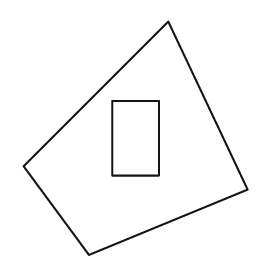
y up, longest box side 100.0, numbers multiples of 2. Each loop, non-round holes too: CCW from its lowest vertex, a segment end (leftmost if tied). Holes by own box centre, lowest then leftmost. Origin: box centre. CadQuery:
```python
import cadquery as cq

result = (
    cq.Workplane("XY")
    .moveTo(-20.0, -50.0)
    .lineTo(48.0, -22.0)
    .lineTo(14.0, 50.0)
    .lineTo(-48.0, -12.0)
    .close()
    .moveTo(-10.0, -16.0)
    .lineTo(10.0, -16.0)
    .lineTo(10.0, 16.0)
    .lineTo(-10.0, 16.0)
    .close()
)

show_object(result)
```